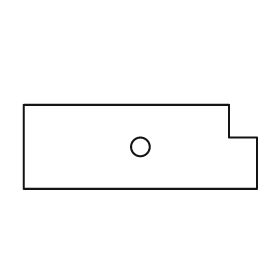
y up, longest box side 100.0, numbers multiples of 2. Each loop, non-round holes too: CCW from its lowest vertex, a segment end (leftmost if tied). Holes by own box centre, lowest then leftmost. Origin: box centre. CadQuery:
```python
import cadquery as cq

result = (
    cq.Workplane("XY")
    .moveTo(-50.0, -18.0)
    .lineTo(50.0, -18.0)
    .lineTo(50.0, 4.0)
    .lineTo(38.0, 4.0)
    .lineTo(38.0, 18.0)
    .lineTo(-50.0, 18.0)
    .close()
    .moveTo(0.0, 0.0)
    .circle(4.0)
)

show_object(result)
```